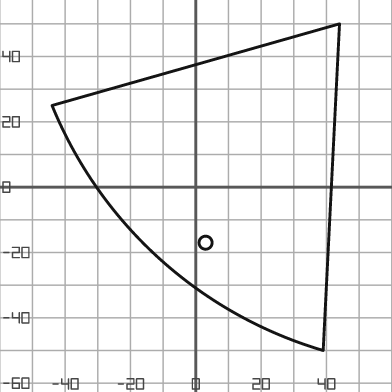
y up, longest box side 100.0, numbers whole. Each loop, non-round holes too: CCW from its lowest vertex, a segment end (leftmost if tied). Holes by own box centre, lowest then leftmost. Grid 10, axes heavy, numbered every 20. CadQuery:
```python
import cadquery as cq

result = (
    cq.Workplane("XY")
    .moveTo(39.0, -50.0)
    .lineTo(44.0, 50.0)
    .lineTo(-44.0, 25.0)
    .threePointArc((-11.0, -22.0), (39.0, -50.0))
    .close()
    .moveTo(3.0, -17.0)
    .circle(2.0)
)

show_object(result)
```